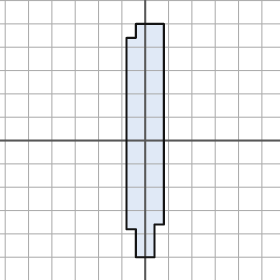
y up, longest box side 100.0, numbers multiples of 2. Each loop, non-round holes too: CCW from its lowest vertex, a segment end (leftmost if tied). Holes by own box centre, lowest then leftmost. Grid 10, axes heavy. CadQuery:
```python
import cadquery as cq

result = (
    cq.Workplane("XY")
    .moveTo(-4.0, -50.0)
    .lineTo(4.0, -50.0)
    .lineTo(4.0, -36.0)
    .lineTo(8.0, -36.0)
    .lineTo(8.0, 50.0)
    .lineTo(-4.0, 50.0)
    .lineTo(-4.0, 44.0)
    .lineTo(-8.0, 44.0)
    .lineTo(-8.0, -38.0)
    .lineTo(-4.0, -38.0)
    .close()
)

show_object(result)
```